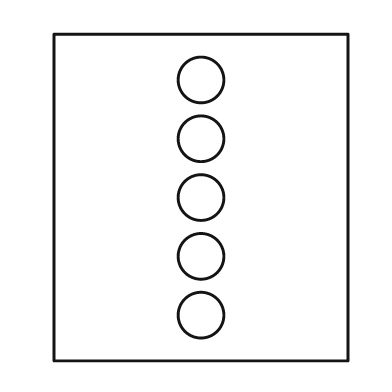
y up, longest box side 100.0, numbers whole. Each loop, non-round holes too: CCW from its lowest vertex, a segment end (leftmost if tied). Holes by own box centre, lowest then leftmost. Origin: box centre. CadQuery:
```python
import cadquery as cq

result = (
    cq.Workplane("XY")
    .moveTo(-45.0, -50.0)
    .lineTo(45.0, -50.0)
    .lineTo(45.0, 50.0)
    .lineTo(-45.0, 50.0)
    .close()
    .moveTo(0.0, -36.0)
    .circle(7.0)
    .moveTo(0.0, -18.0)
    .circle(7.0)
    .moveTo(0.0, 0.0)
    .circle(7.0)
    .moveTo(0.0, 18.0)
    .circle(7.0)
    .moveTo(0.0, 36.0)
    .circle(7.0)
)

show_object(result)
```